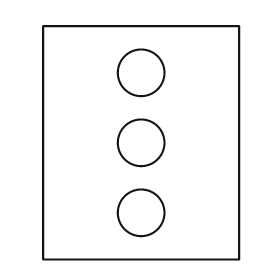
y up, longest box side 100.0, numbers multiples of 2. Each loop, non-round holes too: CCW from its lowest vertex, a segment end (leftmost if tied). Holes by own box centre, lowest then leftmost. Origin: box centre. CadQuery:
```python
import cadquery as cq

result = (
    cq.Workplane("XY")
    .moveTo(-42.0, -50.0)
    .lineTo(42.0, -50.0)
    .lineTo(42.0, 50.0)
    .lineTo(-42.0, 50.0)
    .close()
    .moveTo(0.0, -30.0)
    .circle(10.0)
    .moveTo(0.0, 0.0)
    .circle(10.0)
    .moveTo(0.0, 30.0)
    .circle(10.0)
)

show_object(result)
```